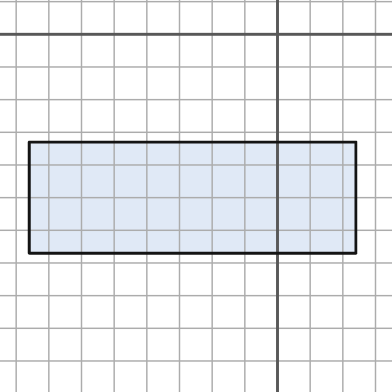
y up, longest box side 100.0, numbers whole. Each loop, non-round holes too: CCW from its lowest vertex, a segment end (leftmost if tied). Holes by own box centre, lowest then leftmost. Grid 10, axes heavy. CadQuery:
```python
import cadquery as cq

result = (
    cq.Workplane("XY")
    .moveTo(-76.0, -67.0)
    .lineTo(24.0, -67.0)
    .lineTo(24.0, -33.0)
    .lineTo(-76.0, -33.0)
    .close()
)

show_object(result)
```